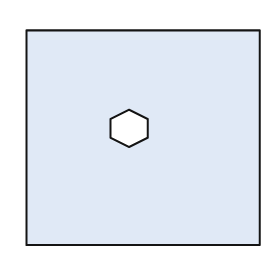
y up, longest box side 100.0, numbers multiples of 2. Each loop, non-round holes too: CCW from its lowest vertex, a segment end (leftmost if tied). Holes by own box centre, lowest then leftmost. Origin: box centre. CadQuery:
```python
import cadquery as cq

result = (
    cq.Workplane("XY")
    .moveTo(-50.0, -46.0)
    .lineTo(50.0, -46.0)
    .lineTo(50.0, 46.0)
    .lineTo(-50.0, 46.0)
    .close()
    .moveTo(-6.0, -4.0)
    .lineTo(2.0, 0.0)
    .lineTo(2.0, 8.0)
    .lineTo(-6.0, 12.0)
    .lineTo(-14.0, 8.0)
    .lineTo(-14.0, 0.0)
    .close()
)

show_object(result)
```